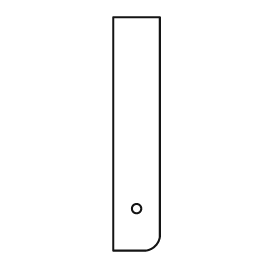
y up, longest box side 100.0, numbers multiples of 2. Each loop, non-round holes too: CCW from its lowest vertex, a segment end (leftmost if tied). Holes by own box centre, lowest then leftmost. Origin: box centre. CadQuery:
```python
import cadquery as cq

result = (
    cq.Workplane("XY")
    .moveTo(-10.0, -50.0)
    .lineTo(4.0, -50.0)
    .threePointArc((8.0, -48.0), (10.0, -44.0))
    .lineTo(10.0, 50.0)
    .lineTo(-10.0, 50.0)
    .close()
    .moveTo(0.0, -32.0)
    .circle(2.0)
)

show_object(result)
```